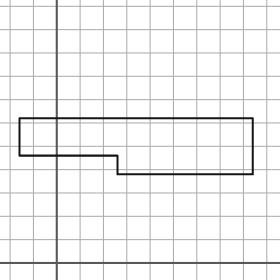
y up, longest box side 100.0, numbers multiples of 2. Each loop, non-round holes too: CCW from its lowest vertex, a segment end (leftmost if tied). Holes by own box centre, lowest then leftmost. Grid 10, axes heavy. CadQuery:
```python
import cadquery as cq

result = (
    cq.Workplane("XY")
    .moveTo(26.0, 38.0)
    .lineTo(84.0, 38.0)
    .lineTo(84.0, 62.0)
    .lineTo(-16.0, 62.0)
    .lineTo(-16.0, 46.0)
    .lineTo(26.0, 46.0)
    .close()
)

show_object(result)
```